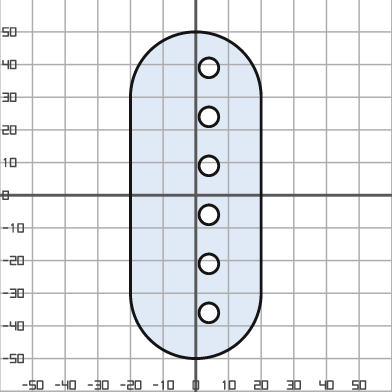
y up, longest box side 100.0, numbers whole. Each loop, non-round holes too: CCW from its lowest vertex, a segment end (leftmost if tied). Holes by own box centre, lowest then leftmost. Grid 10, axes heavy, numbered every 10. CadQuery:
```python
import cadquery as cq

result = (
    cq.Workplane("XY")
    .moveTo(-20.0, -30.0)
    .threePointArc((0.0, -50.0), (20.0, -30.0))
    .lineTo(20.0, 30.0)
    .threePointArc((0.0, 50.0), (-20.0, 30.0))
    .close()
    .moveTo(4.0, -36.0)
    .circle(3.0)
    .moveTo(4.0, -21.0)
    .circle(3.0)
    .moveTo(4.0, -6.0)
    .circle(3.0)
    .moveTo(4.0, 9.0)
    .circle(3.0)
    .moveTo(4.0, 24.0)
    .circle(3.0)
    .moveTo(4.0, 39.0)
    .circle(3.0)
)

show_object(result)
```